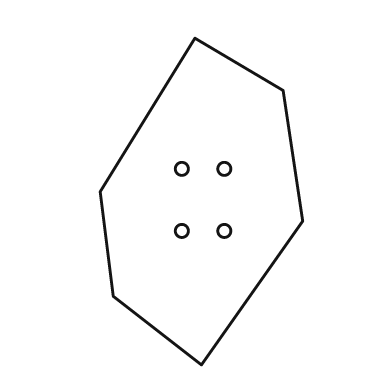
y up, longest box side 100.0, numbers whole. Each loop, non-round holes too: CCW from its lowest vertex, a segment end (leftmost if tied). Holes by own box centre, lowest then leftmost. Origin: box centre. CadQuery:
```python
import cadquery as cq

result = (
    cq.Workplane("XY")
    .moveTo(0.0, -50.0)
    .lineTo(31.0, -6.0)
    .lineTo(25.0, 34.0)
    .lineTo(-2.0, 50.0)
    .lineTo(-31.0, 3.0)
    .lineTo(-27.0, -29.0)
    .close()
    .moveTo(-6.0, -9.0)
    .circle(2.0)
    .moveTo(7.0, -9.0)
    .circle(2.0)
    .moveTo(-6.0, 10.0)
    .circle(2.0)
    .moveTo(7.0, 10.0)
    .circle(2.0)
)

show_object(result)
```